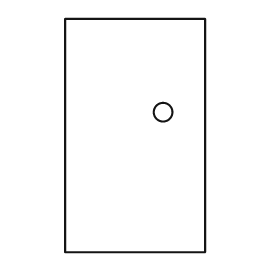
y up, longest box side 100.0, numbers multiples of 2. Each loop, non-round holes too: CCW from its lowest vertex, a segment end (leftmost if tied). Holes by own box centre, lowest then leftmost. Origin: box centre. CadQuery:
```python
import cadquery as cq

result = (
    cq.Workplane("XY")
    .moveTo(-30.0, -50.0)
    .lineTo(30.0, -50.0)
    .lineTo(30.0, 50.0)
    .lineTo(-30.0, 50.0)
    .close()
    .moveTo(12.0, 10.0)
    .circle(4.0)
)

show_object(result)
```